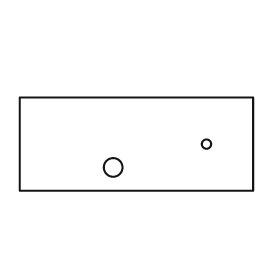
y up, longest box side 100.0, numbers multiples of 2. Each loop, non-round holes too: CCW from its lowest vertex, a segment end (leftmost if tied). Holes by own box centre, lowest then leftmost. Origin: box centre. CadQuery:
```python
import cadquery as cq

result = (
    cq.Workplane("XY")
    .moveTo(-50.0, -20.0)
    .lineTo(50.0, -20.0)
    .lineTo(50.0, 20.0)
    .lineTo(-50.0, 20.0)
    .close()
    .moveTo(-10.0, -10.0)
    .circle(4.0)
    .moveTo(30.0, 0.0)
    .circle(2.0)
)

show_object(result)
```